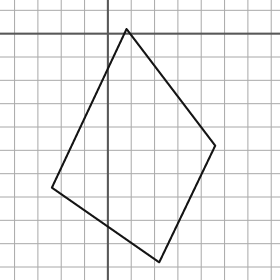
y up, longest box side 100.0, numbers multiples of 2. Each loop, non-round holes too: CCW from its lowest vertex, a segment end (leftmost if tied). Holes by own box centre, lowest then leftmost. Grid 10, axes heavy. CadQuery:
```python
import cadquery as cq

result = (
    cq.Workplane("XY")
    .moveTo(22.0, -98.0)
    .lineTo(46.0, -48.0)
    .lineTo(8.0, 2.0)
    .lineTo(-24.0, -66.0)
    .close()
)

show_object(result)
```